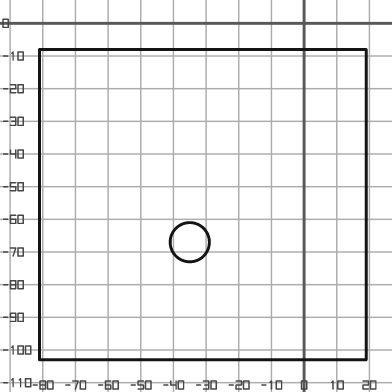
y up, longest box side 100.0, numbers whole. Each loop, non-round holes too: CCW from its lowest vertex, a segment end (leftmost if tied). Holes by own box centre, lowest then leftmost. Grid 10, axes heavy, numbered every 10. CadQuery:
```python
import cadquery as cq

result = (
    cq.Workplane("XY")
    .moveTo(-81.0, -103.0)
    .lineTo(19.0, -103.0)
    .lineTo(19.0, -8.0)
    .lineTo(-81.0, -8.0)
    .close()
    .moveTo(-35.0, -67.0)
    .circle(6.0)
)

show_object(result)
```